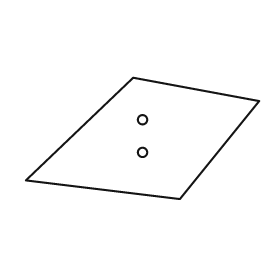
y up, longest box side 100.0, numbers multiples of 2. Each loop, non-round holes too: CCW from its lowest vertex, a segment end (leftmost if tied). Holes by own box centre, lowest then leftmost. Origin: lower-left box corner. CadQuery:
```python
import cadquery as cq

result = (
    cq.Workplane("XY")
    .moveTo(66.0, 0.0)
    .lineTo(100.0, 42.0)
    .lineTo(46.0, 52.0)
    .lineTo(0.0, 8.0)
    .close()
    .moveTo(50.0, 20.0)
    .circle(2.0)
    .moveTo(50.0, 34.0)
    .circle(2.0)
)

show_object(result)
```